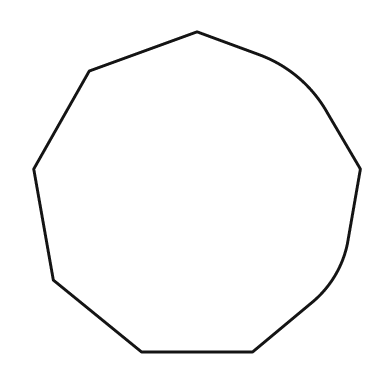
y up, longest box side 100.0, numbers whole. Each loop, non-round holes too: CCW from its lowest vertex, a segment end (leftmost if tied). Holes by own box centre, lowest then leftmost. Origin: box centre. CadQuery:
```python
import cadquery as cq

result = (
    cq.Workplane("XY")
    .moveTo(-17.0, -49.0)
    .lineTo(17.0, -49.0)
    .lineTo(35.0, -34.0)
    .threePointArc((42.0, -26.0), (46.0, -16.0))
    .lineTo(50.0, 7.0)
    .lineTo(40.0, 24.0)
    .threePointArc((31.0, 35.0), (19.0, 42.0))
    .lineTo(0.0, 49.0)
    .lineTo(-33.0, 37.0)
    .lineTo(-50.0, 7.0)
    .lineTo(-44.0, -27.0)
    .close()
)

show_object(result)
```